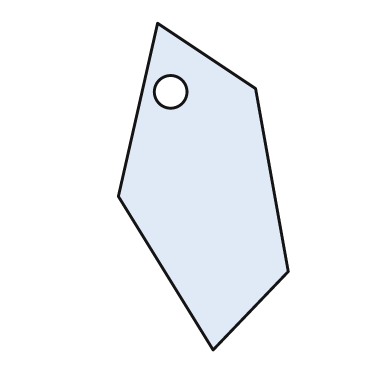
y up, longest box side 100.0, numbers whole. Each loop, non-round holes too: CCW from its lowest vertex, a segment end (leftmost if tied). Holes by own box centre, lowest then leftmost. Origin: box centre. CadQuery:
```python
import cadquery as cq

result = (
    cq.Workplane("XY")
    .moveTo(3.0, -50.0)
    .lineTo(26.0, -26.0)
    .lineTo(16.0, 30.0)
    .lineTo(-14.0, 50.0)
    .lineTo(-26.0, -3.0)
    .close()
    .moveTo(-10.0, 29.0)
    .circle(5.0)
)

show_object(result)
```